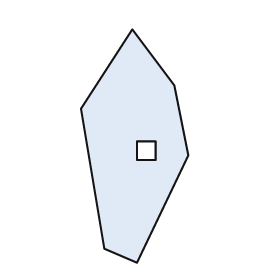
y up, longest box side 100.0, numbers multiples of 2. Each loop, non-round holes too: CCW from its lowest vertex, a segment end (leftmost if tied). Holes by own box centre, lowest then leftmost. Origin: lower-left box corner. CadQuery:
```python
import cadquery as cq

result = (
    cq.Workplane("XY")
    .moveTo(24.0, 0.0)
    .lineTo(46.0, 46.0)
    .lineTo(40.0, 76.0)
    .lineTo(22.0, 100.0)
    .lineTo(0.0, 66.0)
    .lineTo(10.0, 6.0)
    .close()
    .moveTo(24.0, 44.0)
    .lineTo(32.0, 44.0)
    .lineTo(32.0, 52.0)
    .lineTo(24.0, 52.0)
    .close()
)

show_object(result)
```